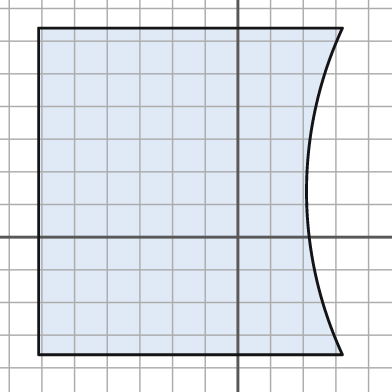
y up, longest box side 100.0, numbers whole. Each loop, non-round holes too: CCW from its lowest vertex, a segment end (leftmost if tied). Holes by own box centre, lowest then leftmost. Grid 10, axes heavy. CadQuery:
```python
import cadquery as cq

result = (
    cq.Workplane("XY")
    .moveTo(-61.0, -36.0)
    .lineTo(32.0, -36.0)
    .threePointArc((21.0, 14.0), (32.0, 64.0))
    .lineTo(-61.0, 64.0)
    .close()
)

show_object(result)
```